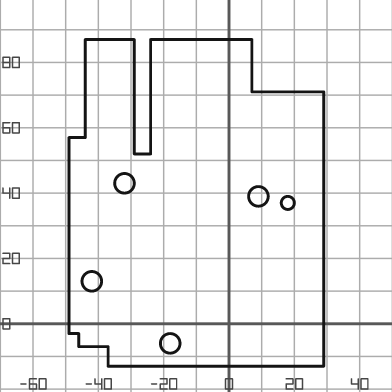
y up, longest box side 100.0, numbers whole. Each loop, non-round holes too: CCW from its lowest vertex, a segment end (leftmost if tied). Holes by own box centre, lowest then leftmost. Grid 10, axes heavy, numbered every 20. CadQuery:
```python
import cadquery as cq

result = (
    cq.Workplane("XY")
    .moveTo(-37.0, -13.0)
    .lineTo(29.0, -13.0)
    .lineTo(29.0, 71.0)
    .lineTo(7.0, 71.0)
    .lineTo(7.0, 87.0)
    .lineTo(-24.0, 87.0)
    .lineTo(-24.0, 52.0)
    .lineTo(-29.0, 52.0)
    .lineTo(-29.0, 87.0)
    .lineTo(-44.0, 87.0)
    .lineTo(-44.0, 57.0)
    .lineTo(-49.0, 57.0)
    .lineTo(-49.0, -3.0)
    .lineTo(-46.0, -3.0)
    .lineTo(-46.0, -7.0)
    .lineTo(-37.0, -7.0)
    .close()
    .moveTo(-18.0, -6.0)
    .circle(3.0)
    .moveTo(-42.0, 13.0)
    .circle(3.0)
    .moveTo(18.0, 37.0)
    .circle(2.0)
    .moveTo(9.0, 39.0)
    .circle(3.0)
    .moveTo(-32.0, 43.0)
    .circle(3.0)
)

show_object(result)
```